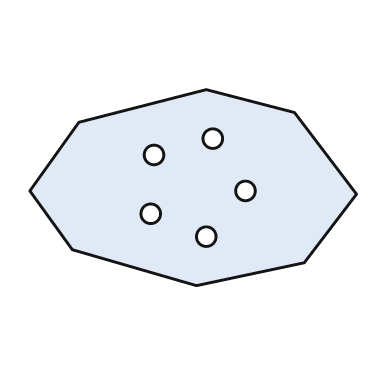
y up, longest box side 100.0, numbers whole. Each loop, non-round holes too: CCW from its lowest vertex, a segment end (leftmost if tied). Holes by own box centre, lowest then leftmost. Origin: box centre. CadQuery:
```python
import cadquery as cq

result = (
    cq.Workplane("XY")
    .moveTo(1.0, -30.0)
    .lineTo(34.0, -23.0)
    .lineTo(50.0, -2.0)
    .lineTo(31.0, 23.0)
    .lineTo(4.0, 30.0)
    .lineTo(-35.0, 20.0)
    .lineTo(-50.0, -1.0)
    .lineTo(-37.0, -19.0)
    .close()
    .moveTo(4.0, -15.0)
    .circle(3.0)
    .moveTo(-13.0, -8.0)
    .circle(3.0)
    .moveTo(16.0, -1.0)
    .circle(3.0)
    .moveTo(-12.0, 10.0)
    .circle(3.0)
    .moveTo(6.0, 15.0)
    .circle(3.0)
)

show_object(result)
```